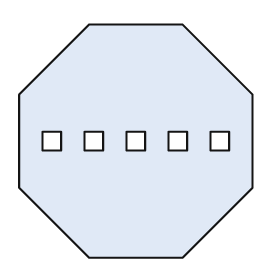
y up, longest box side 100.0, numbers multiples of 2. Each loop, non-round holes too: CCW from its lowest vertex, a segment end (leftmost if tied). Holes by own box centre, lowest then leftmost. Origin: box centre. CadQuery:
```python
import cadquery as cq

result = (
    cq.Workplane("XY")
    .moveTo(-20.0, -50.0)
    .lineTo(20.0, -50.0)
    .lineTo(50.0, -20.0)
    .lineTo(50.0, 20.0)
    .lineTo(20.0, 50.0)
    .lineTo(-20.0, 50.0)
    .lineTo(-50.0, 20.0)
    .lineTo(-50.0, -20.0)
    .close()
    .moveTo(-40.0, -4.0)
    .lineTo(-32.0, -4.0)
    .lineTo(-32.0, 4.0)
    .lineTo(-40.0, 4.0)
    .close()
    .moveTo(-22.0, -4.0)
    .lineTo(-14.0, -4.0)
    .lineTo(-14.0, 4.0)
    .lineTo(-22.0, 4.0)
    .close()
    .moveTo(-4.0, -4.0)
    .lineTo(4.0, -4.0)
    .lineTo(4.0, 4.0)
    .lineTo(-4.0, 4.0)
    .close()
    .moveTo(14.0, -4.0)
    .lineTo(22.0, -4.0)
    .lineTo(22.0, 4.0)
    .lineTo(14.0, 4.0)
    .close()
    .moveTo(32.0, -4.0)
    .lineTo(40.0, -4.0)
    .lineTo(40.0, 4.0)
    .lineTo(32.0, 4.0)
    .close()
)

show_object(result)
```